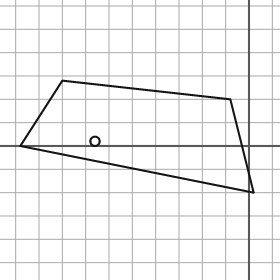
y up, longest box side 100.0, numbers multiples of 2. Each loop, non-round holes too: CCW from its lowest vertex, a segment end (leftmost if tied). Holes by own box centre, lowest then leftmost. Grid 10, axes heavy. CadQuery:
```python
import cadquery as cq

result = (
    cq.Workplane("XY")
    .moveTo(2.0, -20.0)
    .lineTo(-8.0, 20.0)
    .lineTo(-80.0, 28.0)
    .lineTo(-98.0, 0.0)
    .close()
    .moveTo(-66.0, 2.0)
    .circle(2.0)
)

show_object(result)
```